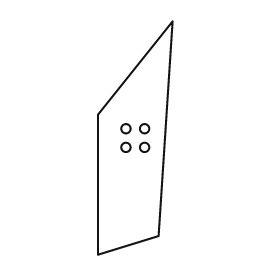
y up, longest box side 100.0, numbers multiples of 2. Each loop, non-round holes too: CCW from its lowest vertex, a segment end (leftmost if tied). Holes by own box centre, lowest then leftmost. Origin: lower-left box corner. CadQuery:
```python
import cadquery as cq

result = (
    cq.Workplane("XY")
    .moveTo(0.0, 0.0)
    .lineTo(26.0, 8.0)
    .lineTo(32.0, 100.0)
    .lineTo(0.0, 60.0)
    .close()
    .moveTo(12.0, 46.0)
    .circle(2.0)
    .moveTo(20.0, 46.0)
    .circle(2.0)
    .moveTo(12.0, 54.0)
    .circle(2.0)
    .moveTo(20.0, 54.0)
    .circle(2.0)
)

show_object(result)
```